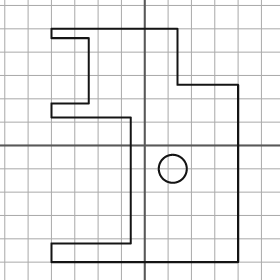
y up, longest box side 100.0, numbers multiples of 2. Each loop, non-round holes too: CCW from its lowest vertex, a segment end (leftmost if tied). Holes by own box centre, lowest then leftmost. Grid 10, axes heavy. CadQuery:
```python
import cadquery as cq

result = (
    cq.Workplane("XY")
    .moveTo(-40.0, -50.0)
    .lineTo(40.0, -50.0)
    .lineTo(40.0, 26.0)
    .lineTo(14.0, 26.0)
    .lineTo(14.0, 50.0)
    .lineTo(-40.0, 50.0)
    .lineTo(-40.0, 46.0)
    .lineTo(-24.0, 46.0)
    .lineTo(-24.0, 18.0)
    .lineTo(-40.0, 18.0)
    .lineTo(-40.0, 12.0)
    .lineTo(-6.0, 12.0)
    .lineTo(-6.0, -42.0)
    .lineTo(-40.0, -42.0)
    .close()
    .moveTo(12.0, -10.0)
    .circle(6.0)
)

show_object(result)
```